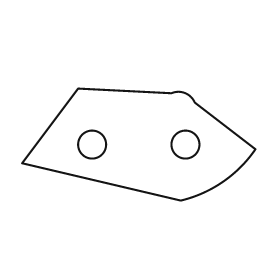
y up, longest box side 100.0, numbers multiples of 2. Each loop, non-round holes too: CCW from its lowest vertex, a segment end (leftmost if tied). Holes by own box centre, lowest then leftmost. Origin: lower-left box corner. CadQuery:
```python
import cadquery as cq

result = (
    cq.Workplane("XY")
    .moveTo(68.0, 0.0)
    .threePointArc((86.0, 8.0), (100.0, 22.0))
    .lineTo(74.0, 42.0)
    .threePointArc((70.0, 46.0), (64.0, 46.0))
    .lineTo(24.0, 48.0)
    .lineTo(0.0, 16.0)
    .close()
    .moveTo(30.0, 24.0)
    .circle(6.0)
    .moveTo(70.0, 24.0)
    .circle(6.0)
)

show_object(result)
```